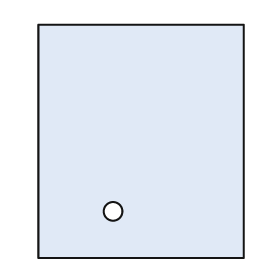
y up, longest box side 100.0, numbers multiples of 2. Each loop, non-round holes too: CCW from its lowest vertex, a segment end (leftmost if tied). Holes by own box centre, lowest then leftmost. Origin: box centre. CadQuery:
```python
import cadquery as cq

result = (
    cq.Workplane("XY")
    .moveTo(-44.0, -50.0)
    .lineTo(44.0, -50.0)
    .lineTo(44.0, 50.0)
    .lineTo(-44.0, 50.0)
    .close()
    .moveTo(-12.0, -30.0)
    .circle(4.0)
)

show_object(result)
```